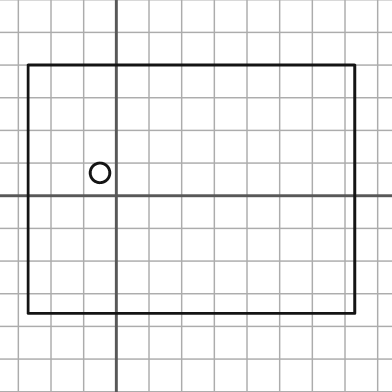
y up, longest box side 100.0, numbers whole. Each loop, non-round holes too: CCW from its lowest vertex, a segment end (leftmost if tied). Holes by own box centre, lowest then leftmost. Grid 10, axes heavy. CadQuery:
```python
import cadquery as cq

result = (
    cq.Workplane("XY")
    .moveTo(-27.0, -36.0)
    .lineTo(73.0, -36.0)
    .lineTo(73.0, 40.0)
    .lineTo(-27.0, 40.0)
    .close()
    .moveTo(-5.0, 7.0)
    .circle(3.0)
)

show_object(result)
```